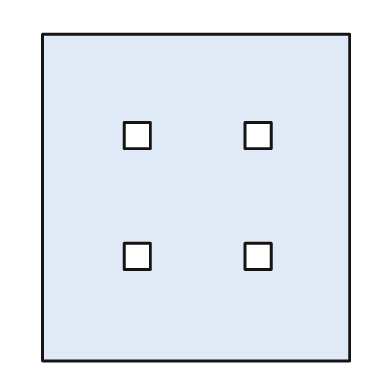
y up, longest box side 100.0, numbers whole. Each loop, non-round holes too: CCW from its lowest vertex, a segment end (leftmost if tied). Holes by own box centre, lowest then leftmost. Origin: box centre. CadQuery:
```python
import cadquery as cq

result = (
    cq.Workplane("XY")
    .moveTo(-47.0, -50.0)
    .lineTo(47.0, -50.0)
    .lineTo(47.0, 50.0)
    .lineTo(-47.0, 50.0)
    .close()
    .moveTo(-22.0, -22.0)
    .lineTo(-14.0, -22.0)
    .lineTo(-14.0, -14.0)
    .lineTo(-22.0, -14.0)
    .close()
    .moveTo(15.0, -22.0)
    .lineTo(23.0, -22.0)
    .lineTo(23.0, -14.0)
    .lineTo(15.0, -14.0)
    .close()
    .moveTo(-22.0, 15.0)
    .lineTo(-14.0, 15.0)
    .lineTo(-14.0, 23.0)
    .lineTo(-22.0, 23.0)
    .close()
    .moveTo(15.0, 15.0)
    .lineTo(23.0, 15.0)
    .lineTo(23.0, 23.0)
    .lineTo(15.0, 23.0)
    .close()
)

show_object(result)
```